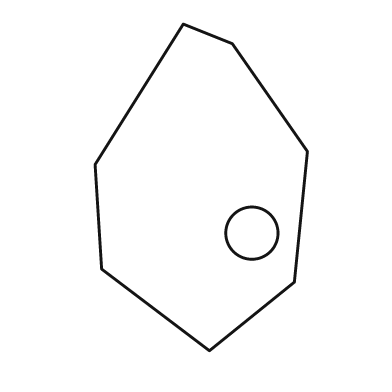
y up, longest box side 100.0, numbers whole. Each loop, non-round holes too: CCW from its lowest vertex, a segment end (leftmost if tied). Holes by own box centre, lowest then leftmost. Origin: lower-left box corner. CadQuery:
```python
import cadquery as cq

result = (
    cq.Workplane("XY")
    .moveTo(35.0, 0.0)
    .lineTo(61.0, 21.0)
    .lineTo(65.0, 61.0)
    .lineTo(42.0, 94.0)
    .lineTo(27.0, 100.0)
    .lineTo(0.0, 57.0)
    .lineTo(2.0, 25.0)
    .close()
    .moveTo(48.0, 36.0)
    .circle(8.0)
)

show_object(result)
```